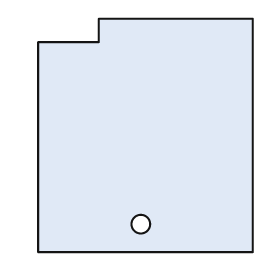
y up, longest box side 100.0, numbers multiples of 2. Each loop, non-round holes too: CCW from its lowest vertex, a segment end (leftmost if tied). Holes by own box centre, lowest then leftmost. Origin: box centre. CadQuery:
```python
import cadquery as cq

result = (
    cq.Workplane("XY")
    .moveTo(-46.0, -50.0)
    .lineTo(46.0, -50.0)
    .lineTo(46.0, 50.0)
    .lineTo(-20.0, 50.0)
    .lineTo(-20.0, 40.0)
    .lineTo(-46.0, 40.0)
    .close()
    .moveTo(-2.0, -38.0)
    .circle(4.0)
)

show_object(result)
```